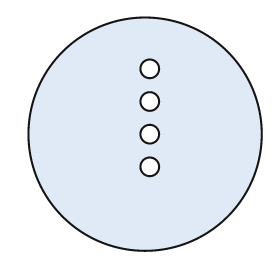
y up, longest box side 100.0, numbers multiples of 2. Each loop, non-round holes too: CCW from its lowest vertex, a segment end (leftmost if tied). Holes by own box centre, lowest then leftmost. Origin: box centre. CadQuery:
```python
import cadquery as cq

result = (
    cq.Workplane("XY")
    .moveTo(0.0, 0.0)
    .circle(50.0)
    .moveTo(2.0, -14.0)
    .circle(4.0)
    .moveTo(2.0, 0.0)
    .circle(4.0)
    .moveTo(2.0, 14.0)
    .circle(4.0)
    .moveTo(2.0, 28.0)
    .circle(4.0)
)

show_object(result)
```